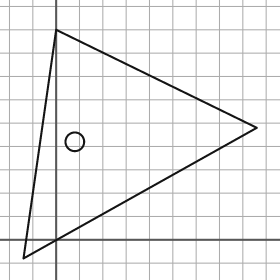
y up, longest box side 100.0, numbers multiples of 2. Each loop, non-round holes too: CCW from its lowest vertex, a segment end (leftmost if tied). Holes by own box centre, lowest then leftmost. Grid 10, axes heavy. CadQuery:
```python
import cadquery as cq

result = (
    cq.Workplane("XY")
    .moveTo(-14.0, -8.0)
    .lineTo(86.0, 48.0)
    .lineTo(0.0, 90.0)
    .close()
    .moveTo(8.0, 42.0)
    .circle(4.0)
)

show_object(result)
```